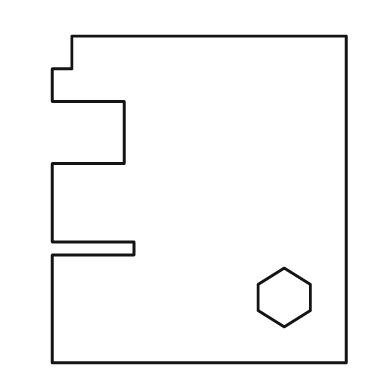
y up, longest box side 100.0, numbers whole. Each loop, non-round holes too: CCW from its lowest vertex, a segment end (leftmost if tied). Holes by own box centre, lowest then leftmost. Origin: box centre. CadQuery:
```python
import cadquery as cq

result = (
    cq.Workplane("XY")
    .moveTo(-45.0, -50.0)
    .lineTo(45.0, -50.0)
    .lineTo(45.0, 50.0)
    .lineTo(-39.0, 50.0)
    .lineTo(-39.0, 40.0)
    .lineTo(-45.0, 40.0)
    .lineTo(-45.0, 30.0)
    .lineTo(-23.0, 30.0)
    .lineTo(-23.0, 11.0)
    .lineTo(-45.0, 11.0)
    .lineTo(-45.0, -13.0)
    .lineTo(-20.0, -13.0)
    .lineTo(-20.0, -17.0)
    .lineTo(-45.0, -17.0)
    .close()
    .moveTo(26.0, -39.0)
    .lineTo(34.0, -34.0)
    .lineTo(34.0, -26.0)
    .lineTo(26.0, -21.0)
    .lineTo(18.0, -26.0)
    .lineTo(18.0, -34.0)
    .close()
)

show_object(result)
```